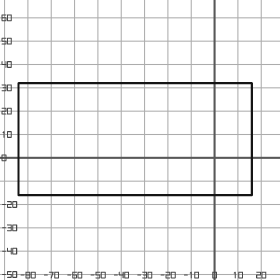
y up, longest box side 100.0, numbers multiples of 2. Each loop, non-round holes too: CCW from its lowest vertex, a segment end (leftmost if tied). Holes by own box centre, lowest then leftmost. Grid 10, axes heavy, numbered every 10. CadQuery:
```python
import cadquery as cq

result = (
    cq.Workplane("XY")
    .moveTo(-84.0, -16.0)
    .lineTo(16.0, -16.0)
    .lineTo(16.0, 32.0)
    .lineTo(-84.0, 32.0)
    .close()
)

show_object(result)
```